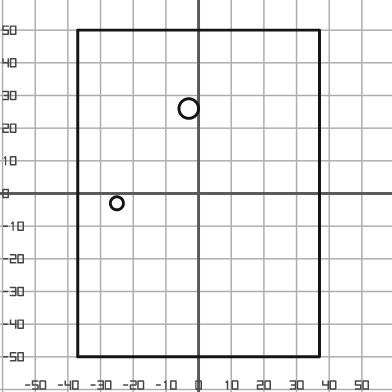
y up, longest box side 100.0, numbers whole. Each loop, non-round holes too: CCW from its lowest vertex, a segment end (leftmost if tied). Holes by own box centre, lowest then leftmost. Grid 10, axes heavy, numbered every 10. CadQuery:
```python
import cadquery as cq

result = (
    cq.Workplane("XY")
    .moveTo(-37.0, -50.0)
    .lineTo(37.0, -50.0)
    .lineTo(37.0, 50.0)
    .lineTo(-37.0, 50.0)
    .close()
    .moveTo(-25.0, -3.0)
    .circle(2.0)
    .moveTo(-3.0, 26.0)
    .circle(3.0)
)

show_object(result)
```